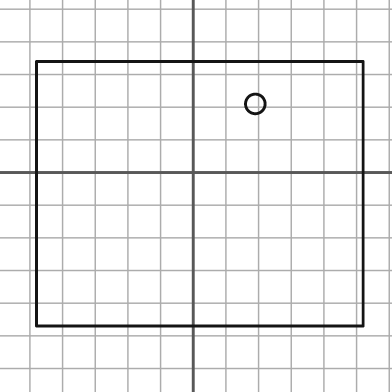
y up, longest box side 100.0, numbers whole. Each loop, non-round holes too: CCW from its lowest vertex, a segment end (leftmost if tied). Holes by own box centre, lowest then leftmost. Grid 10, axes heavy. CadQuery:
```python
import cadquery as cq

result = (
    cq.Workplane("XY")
    .moveTo(-48.0, -47.0)
    .lineTo(52.0, -47.0)
    .lineTo(52.0, 34.0)
    .lineTo(-48.0, 34.0)
    .close()
    .moveTo(19.0, 21.0)
    .circle(3.0)
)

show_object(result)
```